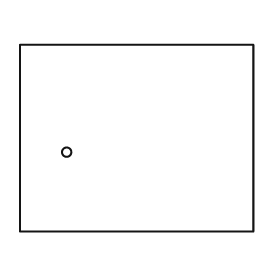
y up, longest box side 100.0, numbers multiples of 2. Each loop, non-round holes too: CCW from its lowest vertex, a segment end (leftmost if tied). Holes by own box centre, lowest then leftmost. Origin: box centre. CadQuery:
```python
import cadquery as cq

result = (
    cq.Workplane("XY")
    .moveTo(-50.0, -40.0)
    .lineTo(50.0, -40.0)
    .lineTo(50.0, 40.0)
    .lineTo(-50.0, 40.0)
    .close()
    .moveTo(-30.0, -6.0)
    .circle(2.0)
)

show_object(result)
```